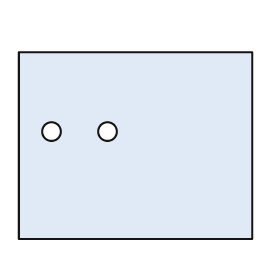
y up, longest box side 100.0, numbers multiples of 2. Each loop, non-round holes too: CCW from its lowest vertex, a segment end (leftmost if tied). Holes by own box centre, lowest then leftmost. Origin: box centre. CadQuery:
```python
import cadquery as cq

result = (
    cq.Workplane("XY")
    .moveTo(-50.0, -40.0)
    .lineTo(50.0, -40.0)
    .lineTo(50.0, 40.0)
    .lineTo(-50.0, 40.0)
    .close()
    .moveTo(-36.0, 6.0)
    .circle(4.0)
    .moveTo(-12.0, 6.0)
    .circle(4.0)
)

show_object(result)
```